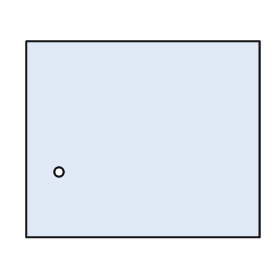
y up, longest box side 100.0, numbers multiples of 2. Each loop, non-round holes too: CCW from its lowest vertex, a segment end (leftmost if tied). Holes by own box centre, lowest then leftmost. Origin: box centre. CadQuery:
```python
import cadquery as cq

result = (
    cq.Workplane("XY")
    .moveTo(-50.0, -42.0)
    .lineTo(50.0, -42.0)
    .lineTo(50.0, 42.0)
    .lineTo(-50.0, 42.0)
    .close()
    .moveTo(-36.0, -14.0)
    .circle(2.0)
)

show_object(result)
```